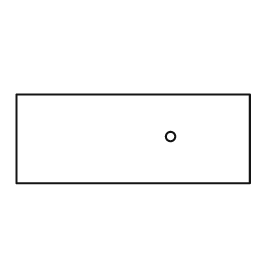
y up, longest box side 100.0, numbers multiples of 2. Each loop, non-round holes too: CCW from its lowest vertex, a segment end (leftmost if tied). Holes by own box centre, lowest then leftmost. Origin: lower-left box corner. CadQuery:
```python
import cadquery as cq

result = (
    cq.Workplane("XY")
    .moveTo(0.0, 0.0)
    .lineTo(100.0, 0.0)
    .lineTo(100.0, 38.0)
    .lineTo(0.0, 38.0)
    .close()
    .moveTo(66.0, 20.0)
    .circle(2.0)
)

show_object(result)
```